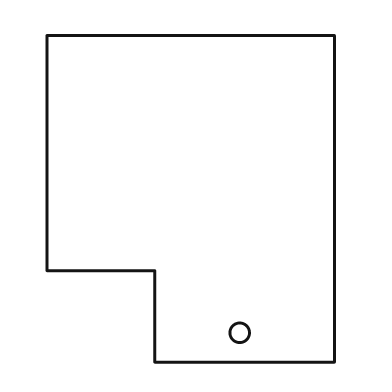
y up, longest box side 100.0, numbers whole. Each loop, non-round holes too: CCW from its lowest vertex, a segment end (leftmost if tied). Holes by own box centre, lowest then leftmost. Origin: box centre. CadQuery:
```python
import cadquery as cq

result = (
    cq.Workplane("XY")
    .moveTo(-11.0, -50.0)
    .lineTo(44.0, -50.0)
    .lineTo(44.0, 50.0)
    .lineTo(-44.0, 50.0)
    .lineTo(-44.0, -22.0)
    .lineTo(-11.0, -22.0)
    .close()
    .moveTo(15.0, -41.0)
    .circle(3.0)
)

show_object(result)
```